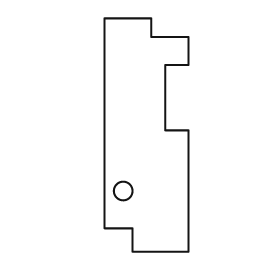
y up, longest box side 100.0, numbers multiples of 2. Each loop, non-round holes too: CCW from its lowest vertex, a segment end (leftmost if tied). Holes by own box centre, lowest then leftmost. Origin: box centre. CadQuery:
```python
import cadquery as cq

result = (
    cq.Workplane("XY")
    .moveTo(-6.0, -50.0)
    .lineTo(18.0, -50.0)
    .lineTo(18.0, 2.0)
    .lineTo(8.0, 2.0)
    .lineTo(8.0, 30.0)
    .lineTo(18.0, 30.0)
    .lineTo(18.0, 42.0)
    .lineTo(2.0, 42.0)
    .lineTo(2.0, 50.0)
    .lineTo(-18.0, 50.0)
    .lineTo(-18.0, -40.0)
    .lineTo(-6.0, -40.0)
    .close()
    .moveTo(-10.0, -24.0)
    .circle(4.0)
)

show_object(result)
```